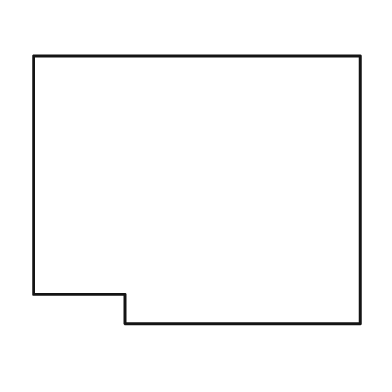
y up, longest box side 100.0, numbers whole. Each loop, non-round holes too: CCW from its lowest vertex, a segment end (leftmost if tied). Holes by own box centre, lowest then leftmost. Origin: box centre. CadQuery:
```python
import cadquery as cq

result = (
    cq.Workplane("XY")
    .moveTo(-22.0, -41.0)
    .lineTo(50.0, -41.0)
    .lineTo(50.0, 41.0)
    .lineTo(-50.0, 41.0)
    .lineTo(-50.0, -32.0)
    .lineTo(-22.0, -32.0)
    .close()
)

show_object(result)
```